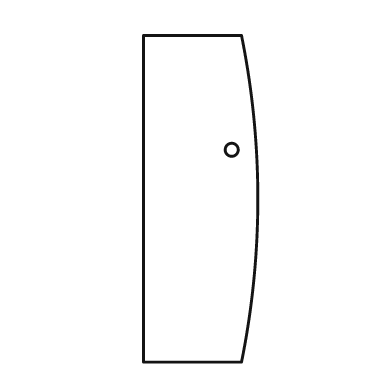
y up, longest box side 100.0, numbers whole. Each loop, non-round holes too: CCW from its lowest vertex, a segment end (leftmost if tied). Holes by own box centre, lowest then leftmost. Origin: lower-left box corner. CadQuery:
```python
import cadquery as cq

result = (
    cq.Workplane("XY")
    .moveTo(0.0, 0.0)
    .lineTo(30.0, 0.0)
    .threePointArc((35.0, 50.0), (30.0, 100.0))
    .lineTo(0.0, 100.0)
    .close()
    .moveTo(27.0, 65.0)
    .circle(2.0)
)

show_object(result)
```